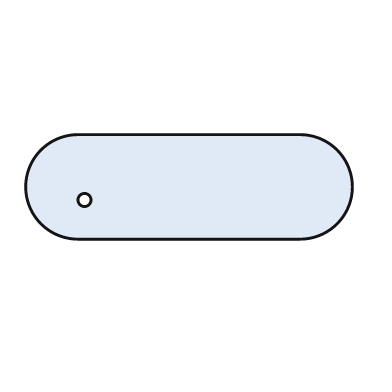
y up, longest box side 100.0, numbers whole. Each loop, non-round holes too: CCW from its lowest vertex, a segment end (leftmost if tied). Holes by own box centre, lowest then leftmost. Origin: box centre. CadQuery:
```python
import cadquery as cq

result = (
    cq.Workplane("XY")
    .moveTo(-34.0, -16.0)
    .lineTo(34.0, -16.0)
    .threePointArc((50.0, 0.0), (34.0, 16.0))
    .lineTo(-34.0, 16.0)
    .threePointArc((-50.0, 0.0), (-34.0, -16.0))
    .close()
    .moveTo(-32.0, -4.0)
    .circle(2.0)
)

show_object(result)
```